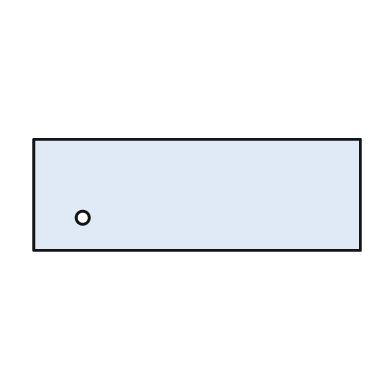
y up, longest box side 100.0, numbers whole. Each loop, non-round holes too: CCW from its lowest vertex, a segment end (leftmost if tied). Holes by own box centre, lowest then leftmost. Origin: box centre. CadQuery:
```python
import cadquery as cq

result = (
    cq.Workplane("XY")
    .moveTo(-50.0, -17.0)
    .lineTo(50.0, -17.0)
    .lineTo(50.0, 17.0)
    .lineTo(-50.0, 17.0)
    .close()
    .moveTo(-35.0, -7.0)
    .circle(2.0)
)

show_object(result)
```